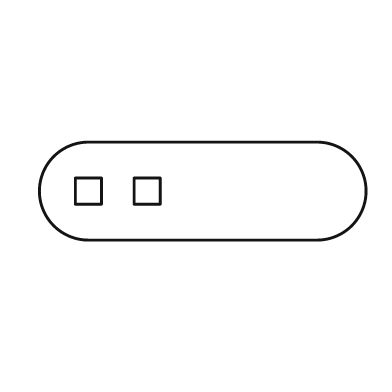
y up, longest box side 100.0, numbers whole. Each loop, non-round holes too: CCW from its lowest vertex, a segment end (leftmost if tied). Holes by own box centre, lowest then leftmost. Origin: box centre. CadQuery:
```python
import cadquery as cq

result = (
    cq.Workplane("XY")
    .moveTo(-35.0, -15.0)
    .lineTo(35.0, -15.0)
    .threePointArc((50.0, 0.0), (35.0, 15.0))
    .lineTo(-35.0, 15.0)
    .threePointArc((-50.0, 0.0), (-35.0, -15.0))
    .close()
    .moveTo(-39.0, -4.0)
    .lineTo(-31.0, -4.0)
    .lineTo(-31.0, 4.0)
    .lineTo(-39.0, 4.0)
    .close()
    .moveTo(-21.0, -4.0)
    .lineTo(-13.0, -4.0)
    .lineTo(-13.0, 4.0)
    .lineTo(-21.0, 4.0)
    .close()
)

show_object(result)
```